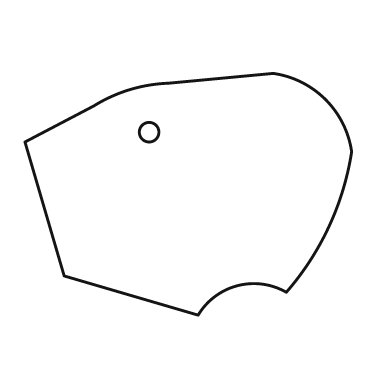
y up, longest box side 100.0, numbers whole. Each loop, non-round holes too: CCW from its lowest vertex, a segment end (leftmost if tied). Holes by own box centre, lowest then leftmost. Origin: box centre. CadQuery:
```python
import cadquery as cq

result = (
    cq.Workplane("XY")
    .moveTo(3.0, -37.0)
    .threePointArc((15.0, -28.0), (30.0, -30.0))
    .threePointArc((43.0, -10.0), (50.0, 13.0))
    .threePointArc((42.0, 29.0), (26.0, 37.0))
    .lineTo(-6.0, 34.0)
    .threePointArc((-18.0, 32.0), (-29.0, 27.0))
    .lineTo(-50.0, 16.0)
    .lineTo(-38.0, -25.0)
    .close()
    .moveTo(-12.0, 19.0)
    .circle(3.0)
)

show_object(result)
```